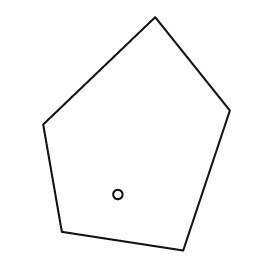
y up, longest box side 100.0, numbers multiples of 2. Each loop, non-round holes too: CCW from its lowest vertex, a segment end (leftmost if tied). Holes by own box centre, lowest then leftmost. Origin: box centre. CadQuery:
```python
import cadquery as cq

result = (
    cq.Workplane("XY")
    .moveTo(20.0, -50.0)
    .lineTo(40.0, 10.0)
    .lineTo(8.0, 50.0)
    .lineTo(-40.0, 4.0)
    .lineTo(-32.0, -42.0)
    .close()
    .moveTo(-8.0, -26.0)
    .circle(2.0)
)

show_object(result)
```